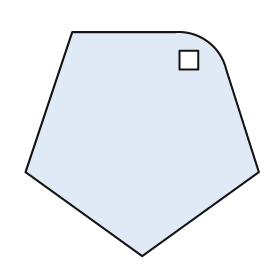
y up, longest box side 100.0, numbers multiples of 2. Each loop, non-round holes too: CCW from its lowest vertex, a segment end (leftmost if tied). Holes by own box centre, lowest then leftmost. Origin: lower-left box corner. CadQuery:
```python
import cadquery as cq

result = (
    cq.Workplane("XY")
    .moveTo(50.0, 0.0)
    .lineTo(100.0, 36.0)
    .lineTo(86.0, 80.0)
    .threePointArc((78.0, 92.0), (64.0, 96.0))
    .lineTo(20.0, 96.0)
    .lineTo(0.0, 36.0)
    .close()
    .moveTo(66.0, 80.0)
    .lineTo(74.0, 80.0)
    .lineTo(74.0, 88.0)
    .lineTo(66.0, 88.0)
    .close()
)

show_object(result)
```